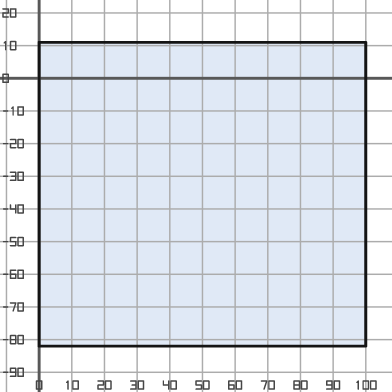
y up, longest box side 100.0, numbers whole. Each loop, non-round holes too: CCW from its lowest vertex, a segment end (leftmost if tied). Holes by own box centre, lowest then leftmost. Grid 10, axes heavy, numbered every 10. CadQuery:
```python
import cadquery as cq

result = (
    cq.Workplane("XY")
    .moveTo(0.0, -82.0)
    .lineTo(100.0, -82.0)
    .lineTo(100.0, 11.0)
    .lineTo(0.0, 11.0)
    .close()
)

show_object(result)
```